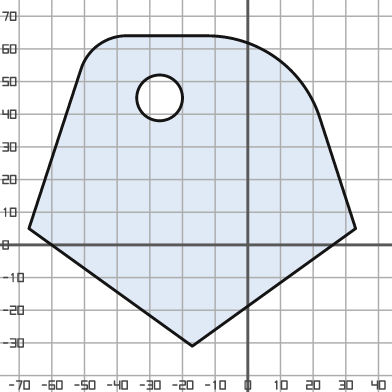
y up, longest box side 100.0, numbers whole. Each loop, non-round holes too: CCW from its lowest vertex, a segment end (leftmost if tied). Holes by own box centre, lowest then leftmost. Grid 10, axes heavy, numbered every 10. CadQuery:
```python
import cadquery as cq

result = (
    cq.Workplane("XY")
    .moveTo(-17.0, -31.0)
    .lineTo(33.0, 5.0)
    .lineTo(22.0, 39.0)
    .threePointArc((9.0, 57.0), (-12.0, 64.0))
    .lineTo(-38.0, 64.0)
    .threePointArc((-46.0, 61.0), (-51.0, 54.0))
    .lineTo(-67.0, 5.0)
    .close()
    .moveTo(-27.0, 45.0)
    .circle(7.0)
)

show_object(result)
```